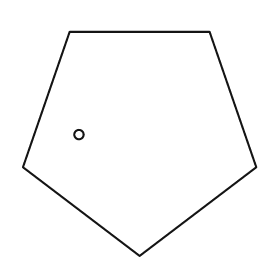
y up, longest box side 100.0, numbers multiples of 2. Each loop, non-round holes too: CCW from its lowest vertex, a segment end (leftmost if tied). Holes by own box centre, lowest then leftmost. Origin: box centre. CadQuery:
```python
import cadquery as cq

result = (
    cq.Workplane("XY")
    .moveTo(0.0, -48.0)
    .lineTo(50.0, -10.0)
    .lineTo(30.0, 48.0)
    .lineTo(-30.0, 48.0)
    .lineTo(-50.0, -10.0)
    .close()
    .moveTo(-26.0, 4.0)
    .circle(2.0)
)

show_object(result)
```